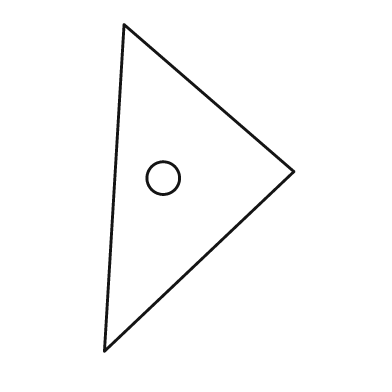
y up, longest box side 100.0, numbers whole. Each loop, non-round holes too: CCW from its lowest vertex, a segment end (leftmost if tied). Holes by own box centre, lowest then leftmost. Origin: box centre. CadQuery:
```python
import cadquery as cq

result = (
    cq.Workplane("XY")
    .moveTo(-29.0, -50.0)
    .lineTo(29.0, 5.0)
    .lineTo(-23.0, 50.0)
    .close()
    .moveTo(-11.0, 3.0)
    .circle(5.0)
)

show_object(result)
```